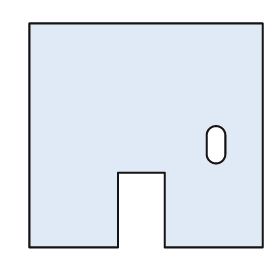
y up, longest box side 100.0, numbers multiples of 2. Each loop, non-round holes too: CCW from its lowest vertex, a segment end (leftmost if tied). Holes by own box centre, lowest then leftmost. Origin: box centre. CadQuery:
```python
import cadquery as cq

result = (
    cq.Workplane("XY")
    .moveTo(-50.0, -48.0)
    .lineTo(-12.0, -48.0)
    .lineTo(-12.0, -16.0)
    .lineTo(8.0, -16.0)
    .lineTo(8.0, -48.0)
    .lineTo(50.0, -48.0)
    .lineTo(50.0, 48.0)
    .lineTo(-50.0, 48.0)
    .close()
    .moveTo(26.0, -8.0)
    .threePointArc((30.0, -12.0), (34.0, -8.0))
    .lineTo(34.0, 0.0)
    .threePointArc((30.0, 4.0), (26.0, 0.0))
    .close()
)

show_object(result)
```